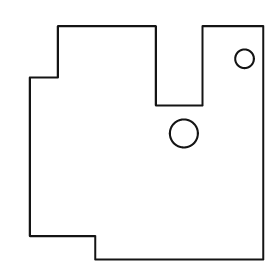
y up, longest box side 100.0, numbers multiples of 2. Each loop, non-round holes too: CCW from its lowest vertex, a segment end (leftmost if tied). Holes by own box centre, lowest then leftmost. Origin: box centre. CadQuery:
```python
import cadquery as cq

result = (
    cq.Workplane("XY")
    .moveTo(-22.0, -50.0)
    .lineTo(50.0, -50.0)
    .lineTo(50.0, 50.0)
    .lineTo(24.0, 50.0)
    .lineTo(24.0, 16.0)
    .lineTo(4.0, 16.0)
    .lineTo(4.0, 50.0)
    .lineTo(-38.0, 50.0)
    .lineTo(-38.0, 28.0)
    .lineTo(-50.0, 28.0)
    .lineTo(-50.0, -40.0)
    .lineTo(-22.0, -40.0)
    .close()
    .moveTo(16.0, 4.0)
    .circle(6.0)
    .moveTo(42.0, 36.0)
    .circle(4.0)
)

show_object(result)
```